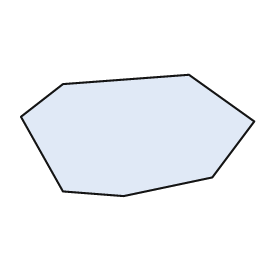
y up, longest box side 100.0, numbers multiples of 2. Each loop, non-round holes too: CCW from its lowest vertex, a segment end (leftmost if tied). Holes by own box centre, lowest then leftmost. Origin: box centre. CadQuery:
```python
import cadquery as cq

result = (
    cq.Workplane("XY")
    .moveTo(-6.0, -26.0)
    .lineTo(32.0, -18.0)
    .lineTo(50.0, 6.0)
    .lineTo(22.0, 26.0)
    .lineTo(-32.0, 22.0)
    .lineTo(-50.0, 8.0)
    .lineTo(-32.0, -24.0)
    .close()
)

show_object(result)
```